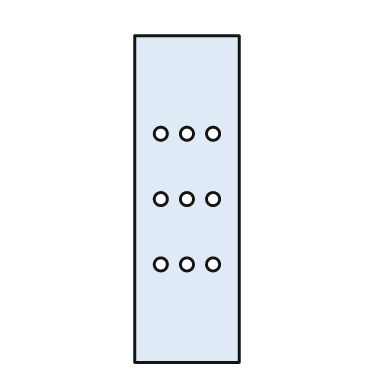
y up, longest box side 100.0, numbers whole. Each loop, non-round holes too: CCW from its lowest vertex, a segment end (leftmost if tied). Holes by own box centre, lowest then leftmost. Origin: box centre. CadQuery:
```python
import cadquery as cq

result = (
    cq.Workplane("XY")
    .moveTo(-16.0, -50.0)
    .lineTo(16.0, -50.0)
    .lineTo(16.0, 50.0)
    .lineTo(-16.0, 50.0)
    .close()
    .moveTo(-8.0, -20.0)
    .circle(2.0)
    .moveTo(0.0, -20.0)
    .circle(2.0)
    .moveTo(8.0, -20.0)
    .circle(2.0)
    .moveTo(-8.0, 0.0)
    .circle(2.0)
    .moveTo(0.0, 0.0)
    .circle(2.0)
    .moveTo(8.0, 0.0)
    .circle(2.0)
    .moveTo(-8.0, 20.0)
    .circle(2.0)
    .moveTo(0.0, 20.0)
    .circle(2.0)
    .moveTo(8.0, 20.0)
    .circle(2.0)
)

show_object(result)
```